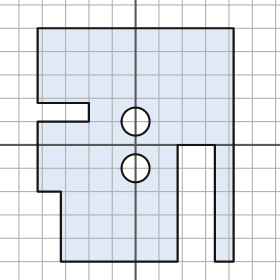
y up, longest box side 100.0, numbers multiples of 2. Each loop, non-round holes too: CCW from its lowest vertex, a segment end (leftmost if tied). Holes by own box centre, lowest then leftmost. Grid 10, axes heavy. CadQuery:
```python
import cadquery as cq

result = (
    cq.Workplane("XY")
    .moveTo(-32.0, -50.0)
    .lineTo(18.0, -50.0)
    .lineTo(18.0, 0.0)
    .lineTo(34.0, 0.0)
    .lineTo(34.0, -50.0)
    .lineTo(42.0, -50.0)
    .lineTo(42.0, 50.0)
    .lineTo(-42.0, 50.0)
    .lineTo(-42.0, 18.0)
    .lineTo(-20.0, 18.0)
    .lineTo(-20.0, 10.0)
    .lineTo(-42.0, 10.0)
    .lineTo(-42.0, -20.0)
    .lineTo(-32.0, -20.0)
    .close()
    .moveTo(0.0, -10.0)
    .circle(6.0)
    .moveTo(0.0, 10.0)
    .circle(6.0)
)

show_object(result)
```